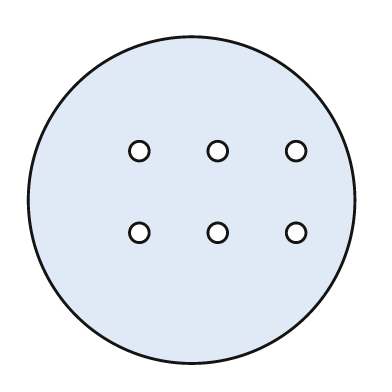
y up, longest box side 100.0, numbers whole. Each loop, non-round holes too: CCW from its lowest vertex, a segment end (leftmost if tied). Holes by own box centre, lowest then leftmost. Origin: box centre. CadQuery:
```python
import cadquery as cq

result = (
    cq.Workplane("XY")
    .moveTo(0.0, 0.0)
    .circle(50.0)
    .moveTo(-16.0, -10.0)
    .circle(3.0)
    .moveTo(8.0, -10.0)
    .circle(3.0)
    .moveTo(32.0, -10.0)
    .circle(3.0)
    .moveTo(-16.0, 15.0)
    .circle(3.0)
    .moveTo(8.0, 15.0)
    .circle(3.0)
    .moveTo(32.0, 15.0)
    .circle(3.0)
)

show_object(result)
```